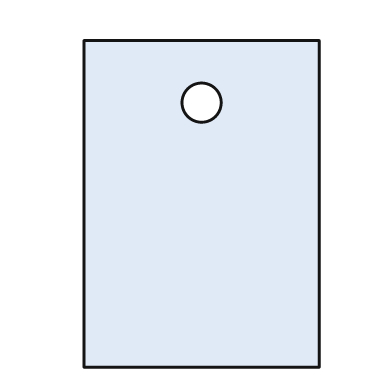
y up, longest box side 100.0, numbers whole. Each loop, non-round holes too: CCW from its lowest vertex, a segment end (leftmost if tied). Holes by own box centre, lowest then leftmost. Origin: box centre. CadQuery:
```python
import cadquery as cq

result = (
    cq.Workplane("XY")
    .moveTo(-36.0, -50.0)
    .lineTo(36.0, -50.0)
    .lineTo(36.0, 50.0)
    .lineTo(-36.0, 50.0)
    .close()
    .moveTo(0.0, 31.0)
    .circle(6.0)
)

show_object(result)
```